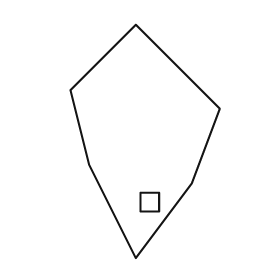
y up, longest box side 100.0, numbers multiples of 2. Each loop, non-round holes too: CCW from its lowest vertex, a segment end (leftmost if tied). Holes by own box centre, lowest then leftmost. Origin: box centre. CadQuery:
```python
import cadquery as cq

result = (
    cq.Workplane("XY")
    .moveTo(-4.0, -50.0)
    .lineTo(20.0, -18.0)
    .lineTo(32.0, 14.0)
    .lineTo(-4.0, 50.0)
    .lineTo(-32.0, 22.0)
    .lineTo(-24.0, -10.0)
    .close()
    .moveTo(-2.0, -30.0)
    .lineTo(6.0, -30.0)
    .lineTo(6.0, -22.0)
    .lineTo(-2.0, -22.0)
    .close()
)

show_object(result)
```